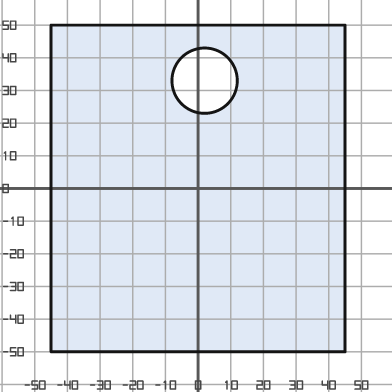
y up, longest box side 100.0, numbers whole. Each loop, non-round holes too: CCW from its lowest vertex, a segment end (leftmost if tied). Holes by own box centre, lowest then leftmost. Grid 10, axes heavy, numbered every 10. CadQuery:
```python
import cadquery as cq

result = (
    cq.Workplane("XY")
    .moveTo(-45.0, -50.0)
    .lineTo(45.0, -50.0)
    .lineTo(45.0, 50.0)
    .lineTo(-45.0, 50.0)
    .close()
    .moveTo(2.0, 33.0)
    .circle(10.0)
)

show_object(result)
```